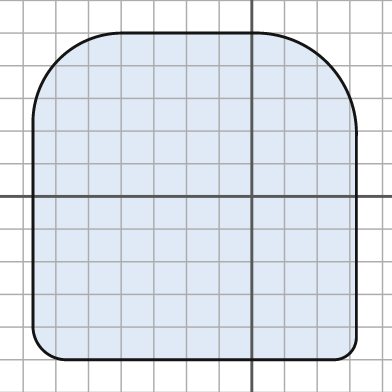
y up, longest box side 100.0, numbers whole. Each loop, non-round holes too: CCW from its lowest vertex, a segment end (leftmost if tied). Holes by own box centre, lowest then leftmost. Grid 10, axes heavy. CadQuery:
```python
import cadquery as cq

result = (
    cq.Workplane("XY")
    .moveTo(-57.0, -50.0)
    .lineTo(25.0, -50.0)
    .threePointArc((30.0, -48.0), (32.0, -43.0))
    .lineTo(32.0, 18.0)
    .threePointArc((23.0, 41.0), (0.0, 50.0))
    .lineTo(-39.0, 50.0)
    .threePointArc((-59.0, 42.0), (-67.0, 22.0))
    .lineTo(-67.0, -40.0)
    .threePointArc((-64.0, -47.0), (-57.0, -50.0))
    .close()
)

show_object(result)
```